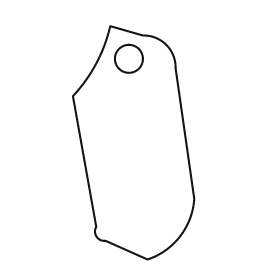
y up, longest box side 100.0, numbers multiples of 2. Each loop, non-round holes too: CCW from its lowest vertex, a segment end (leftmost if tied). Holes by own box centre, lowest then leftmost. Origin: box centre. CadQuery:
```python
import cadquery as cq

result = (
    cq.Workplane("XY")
    .moveTo(6.0, -50.0)
    .threePointArc((20.0, -40.0), (26.0, -24.0))
    .lineTo(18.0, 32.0)
    .threePointArc((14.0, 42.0), (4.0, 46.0))
    .lineTo(-10.0, 50.0)
    .threePointArc((-16.0, 34.0), (-26.0, 20.0))
    .lineTo(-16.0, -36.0)
    .threePointArc((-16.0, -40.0), (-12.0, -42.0))
    .close()
    .moveTo(-2.0, 36.0)
    .circle(6.0)
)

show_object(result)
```